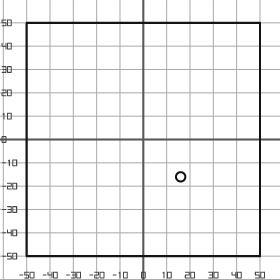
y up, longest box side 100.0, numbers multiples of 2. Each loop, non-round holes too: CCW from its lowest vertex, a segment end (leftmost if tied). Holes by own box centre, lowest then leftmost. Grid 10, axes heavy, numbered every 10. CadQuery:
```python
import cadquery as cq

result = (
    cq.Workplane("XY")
    .moveTo(-50.0, -50.0)
    .lineTo(50.0, -50.0)
    .lineTo(50.0, 50.0)
    .lineTo(-50.0, 50.0)
    .close()
    .moveTo(16.0, -16.0)
    .circle(2.0)
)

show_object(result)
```